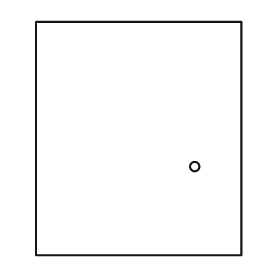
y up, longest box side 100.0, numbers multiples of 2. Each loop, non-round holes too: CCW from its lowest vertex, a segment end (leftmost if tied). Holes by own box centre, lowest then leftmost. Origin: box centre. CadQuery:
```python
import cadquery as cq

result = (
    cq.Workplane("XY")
    .moveTo(-44.0, -50.0)
    .lineTo(44.0, -50.0)
    .lineTo(44.0, 50.0)
    .lineTo(-44.0, 50.0)
    .close()
    .moveTo(24.0, -12.0)
    .circle(2.0)
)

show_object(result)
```